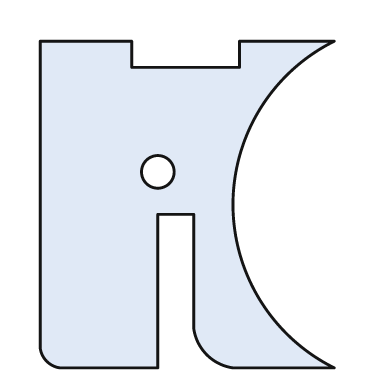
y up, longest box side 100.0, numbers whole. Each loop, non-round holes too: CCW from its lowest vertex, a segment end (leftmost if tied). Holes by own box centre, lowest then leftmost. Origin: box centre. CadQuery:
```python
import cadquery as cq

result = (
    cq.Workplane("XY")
    .moveTo(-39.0, -50.0)
    .lineTo(-9.0, -50.0)
    .lineTo(-9.0, -3.0)
    .lineTo(2.0, -3.0)
    .lineTo(2.0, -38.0)
    .threePointArc((6.0, -46.0), (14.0, -50.0))
    .lineTo(45.0, -50.0)
    .threePointArc((14.0, 0.0), (45.0, 50.0))
    .lineTo(16.0, 50.0)
    .lineTo(16.0, 42.0)
    .lineTo(-17.0, 42.0)
    .lineTo(-17.0, 50.0)
    .lineTo(-45.0, 50.0)
    .lineTo(-45.0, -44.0)
    .threePointArc((-43.0, -48.0), (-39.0, -50.0))
    .close()
    .moveTo(-9.0, 10.0)
    .circle(5.0)
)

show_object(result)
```